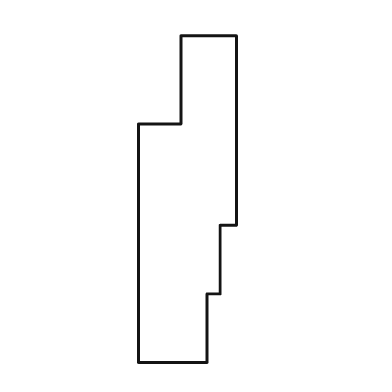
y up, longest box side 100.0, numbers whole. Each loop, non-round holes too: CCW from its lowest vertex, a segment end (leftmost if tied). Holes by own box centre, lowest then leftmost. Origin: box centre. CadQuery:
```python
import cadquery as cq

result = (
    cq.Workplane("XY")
    .moveTo(-15.0, -50.0)
    .lineTo(6.0, -50.0)
    .lineTo(6.0, -29.0)
    .lineTo(10.0, -29.0)
    .lineTo(10.0, -8.0)
    .lineTo(15.0, -8.0)
    .lineTo(15.0, 50.0)
    .lineTo(-2.0, 50.0)
    .lineTo(-2.0, 23.0)
    .lineTo(-15.0, 23.0)
    .close()
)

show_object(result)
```